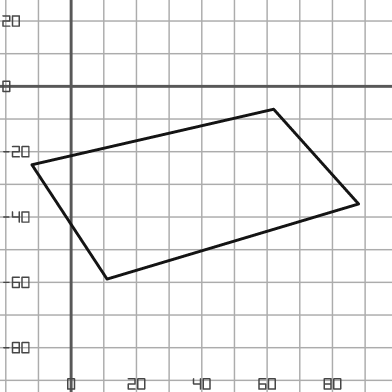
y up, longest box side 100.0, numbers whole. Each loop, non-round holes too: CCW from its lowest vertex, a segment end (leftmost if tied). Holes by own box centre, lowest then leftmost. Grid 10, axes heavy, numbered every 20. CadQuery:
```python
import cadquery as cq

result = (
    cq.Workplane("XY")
    .moveTo(11.0, -59.0)
    .lineTo(88.0, -36.0)
    .lineTo(62.0, -7.0)
    .lineTo(-12.0, -24.0)
    .close()
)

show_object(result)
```